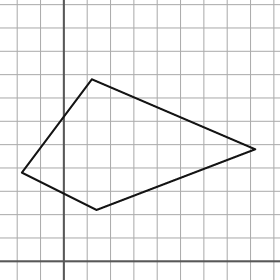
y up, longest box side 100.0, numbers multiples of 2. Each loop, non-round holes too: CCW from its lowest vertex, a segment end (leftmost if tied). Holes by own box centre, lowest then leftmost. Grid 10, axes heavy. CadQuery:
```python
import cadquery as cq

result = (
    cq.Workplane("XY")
    .moveTo(14.0, 22.0)
    .lineTo(82.0, 48.0)
    .lineTo(12.0, 78.0)
    .lineTo(-18.0, 38.0)
    .close()
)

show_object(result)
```